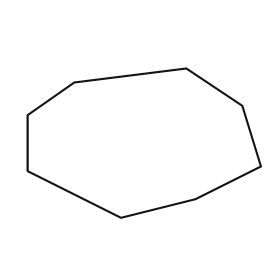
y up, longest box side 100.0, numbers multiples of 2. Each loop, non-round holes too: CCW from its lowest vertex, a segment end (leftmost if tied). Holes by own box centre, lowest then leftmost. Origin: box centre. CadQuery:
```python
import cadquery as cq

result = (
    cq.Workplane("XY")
    .moveTo(-10.0, -32.0)
    .lineTo(22.0, -24.0)
    .lineTo(50.0, -10.0)
    .lineTo(42.0, 16.0)
    .lineTo(18.0, 32.0)
    .lineTo(-30.0, 26.0)
    .lineTo(-50.0, 12.0)
    .lineTo(-50.0, -12.0)
    .close()
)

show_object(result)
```